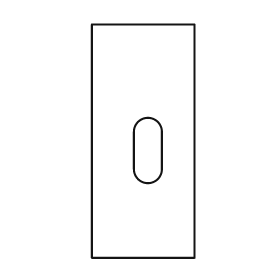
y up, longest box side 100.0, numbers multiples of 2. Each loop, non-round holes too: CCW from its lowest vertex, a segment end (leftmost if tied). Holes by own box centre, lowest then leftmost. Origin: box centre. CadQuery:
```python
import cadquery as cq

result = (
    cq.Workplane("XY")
    .moveTo(-22.0, -50.0)
    .lineTo(22.0, -50.0)
    .lineTo(22.0, 50.0)
    .lineTo(-22.0, 50.0)
    .close()
    .moveTo(-4.0, -12.0)
    .threePointArc((2.0, -18.0), (8.0, -12.0))
    .lineTo(8.0, 4.0)
    .threePointArc((2.0, 10.0), (-4.0, 4.0))
    .close()
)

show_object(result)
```